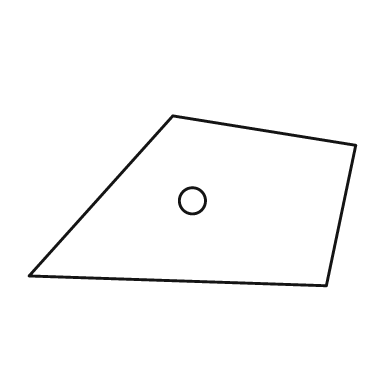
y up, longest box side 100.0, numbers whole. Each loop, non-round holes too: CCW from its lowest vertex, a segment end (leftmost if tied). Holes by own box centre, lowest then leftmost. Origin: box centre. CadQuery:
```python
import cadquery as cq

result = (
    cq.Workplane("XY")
    .moveTo(41.0, -26.0)
    .lineTo(50.0, 17.0)
    .lineTo(-6.0, 26.0)
    .lineTo(-50.0, -23.0)
    .close()
    .moveTo(0.0, 0.0)
    .circle(4.0)
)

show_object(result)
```